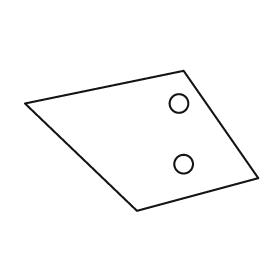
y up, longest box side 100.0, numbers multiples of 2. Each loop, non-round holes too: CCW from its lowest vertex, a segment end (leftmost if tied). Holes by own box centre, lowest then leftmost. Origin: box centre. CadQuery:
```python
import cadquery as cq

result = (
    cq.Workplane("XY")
    .moveTo(-2.0, -30.0)
    .lineTo(50.0, -16.0)
    .lineTo(18.0, 30.0)
    .lineTo(-50.0, 16.0)
    .close()
    .moveTo(18.0, -10.0)
    .circle(4.0)
    .moveTo(16.0, 16.0)
    .circle(4.0)
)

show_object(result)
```